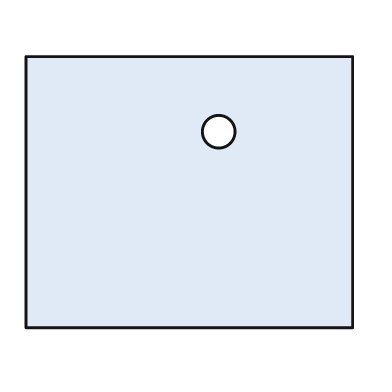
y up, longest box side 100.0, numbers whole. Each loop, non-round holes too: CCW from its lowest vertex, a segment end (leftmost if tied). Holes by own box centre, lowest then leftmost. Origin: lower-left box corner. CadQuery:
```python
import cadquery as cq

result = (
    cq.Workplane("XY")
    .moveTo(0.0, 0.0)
    .lineTo(100.0, 0.0)
    .lineTo(100.0, 83.0)
    .lineTo(0.0, 83.0)
    .close()
    .moveTo(59.0, 60.0)
    .circle(5.0)
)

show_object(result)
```